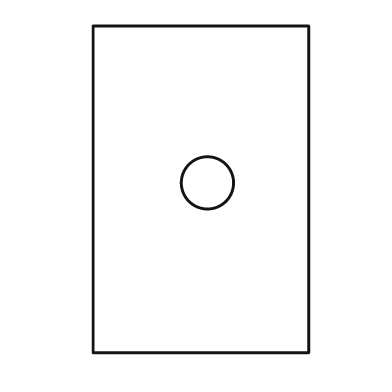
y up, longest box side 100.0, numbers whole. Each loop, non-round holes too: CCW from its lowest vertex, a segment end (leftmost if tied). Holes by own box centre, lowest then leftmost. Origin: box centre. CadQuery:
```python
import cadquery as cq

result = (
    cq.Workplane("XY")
    .moveTo(-33.0, -50.0)
    .lineTo(33.0, -50.0)
    .lineTo(33.0, 50.0)
    .lineTo(-33.0, 50.0)
    .close()
    .moveTo(2.0, 2.0)
    .circle(8.0)
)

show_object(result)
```